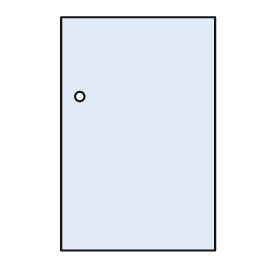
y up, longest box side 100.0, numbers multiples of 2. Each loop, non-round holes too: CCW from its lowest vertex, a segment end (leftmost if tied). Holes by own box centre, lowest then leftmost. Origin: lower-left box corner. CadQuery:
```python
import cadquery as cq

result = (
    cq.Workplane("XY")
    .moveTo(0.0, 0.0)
    .lineTo(66.0, 0.0)
    .lineTo(66.0, 100.0)
    .lineTo(0.0, 100.0)
    .close()
    .moveTo(8.0, 66.0)
    .circle(2.0)
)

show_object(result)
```